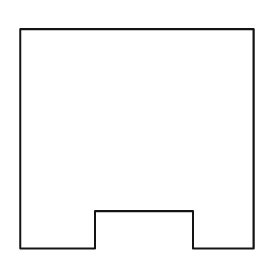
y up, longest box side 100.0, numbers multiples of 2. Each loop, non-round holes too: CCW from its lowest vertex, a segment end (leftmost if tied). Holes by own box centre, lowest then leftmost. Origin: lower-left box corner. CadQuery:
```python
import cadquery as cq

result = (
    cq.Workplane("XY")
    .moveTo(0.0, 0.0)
    .lineTo(32.0, 0.0)
    .lineTo(32.0, 16.0)
    .lineTo(74.0, 16.0)
    .lineTo(74.0, 0.0)
    .lineTo(100.0, 0.0)
    .lineTo(100.0, 94.0)
    .lineTo(0.0, 94.0)
    .close()
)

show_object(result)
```